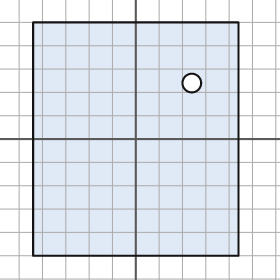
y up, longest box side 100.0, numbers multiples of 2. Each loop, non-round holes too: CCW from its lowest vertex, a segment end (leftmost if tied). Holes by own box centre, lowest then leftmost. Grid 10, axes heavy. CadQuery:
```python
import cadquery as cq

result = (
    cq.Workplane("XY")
    .moveTo(-44.0, -50.0)
    .lineTo(44.0, -50.0)
    .lineTo(44.0, 50.0)
    .lineTo(-44.0, 50.0)
    .close()
    .moveTo(24.0, 24.0)
    .circle(4.0)
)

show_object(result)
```